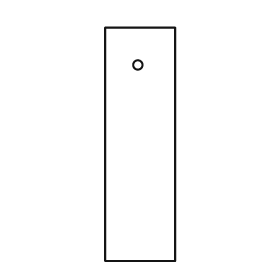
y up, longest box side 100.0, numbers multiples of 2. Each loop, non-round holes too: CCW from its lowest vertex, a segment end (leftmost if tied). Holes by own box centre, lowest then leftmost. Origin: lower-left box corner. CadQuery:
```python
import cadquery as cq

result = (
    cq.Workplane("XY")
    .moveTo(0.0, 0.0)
    .lineTo(30.0, 0.0)
    .lineTo(30.0, 100.0)
    .lineTo(0.0, 100.0)
    .close()
    .moveTo(14.0, 84.0)
    .circle(2.0)
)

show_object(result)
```